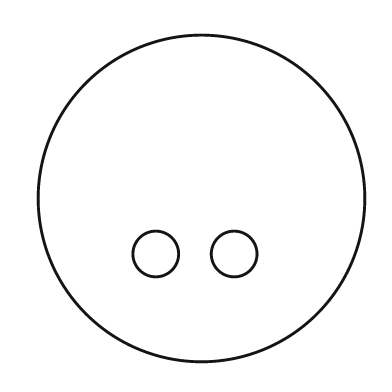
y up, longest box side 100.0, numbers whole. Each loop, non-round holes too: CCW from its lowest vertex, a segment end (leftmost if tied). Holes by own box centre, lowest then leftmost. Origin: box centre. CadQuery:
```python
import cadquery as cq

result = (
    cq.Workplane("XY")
    .moveTo(0.0, 0.0)
    .circle(50.0)
    .moveTo(-14.0, -17.0)
    .circle(7.0)
    .moveTo(10.0, -17.0)
    .circle(7.0)
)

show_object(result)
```